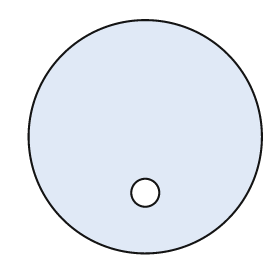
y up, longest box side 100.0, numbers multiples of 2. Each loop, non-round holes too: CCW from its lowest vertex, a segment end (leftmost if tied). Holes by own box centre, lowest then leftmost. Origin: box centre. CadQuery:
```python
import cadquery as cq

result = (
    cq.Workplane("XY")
    .moveTo(0.0, 0.0)
    .circle(50.0)
    .moveTo(0.0, -24.0)
    .circle(6.0)
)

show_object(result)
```